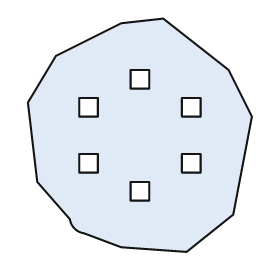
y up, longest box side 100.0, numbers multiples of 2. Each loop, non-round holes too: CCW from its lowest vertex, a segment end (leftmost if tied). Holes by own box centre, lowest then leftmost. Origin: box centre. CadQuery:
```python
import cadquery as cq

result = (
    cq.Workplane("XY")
    .moveTo(20.0, -50.0)
    .lineTo(40.0, -34.0)
    .lineTo(48.0, 8.0)
    .lineTo(38.0, 28.0)
    .lineTo(10.0, 50.0)
    .lineTo(-8.0, 48.0)
    .lineTo(-36.0, 34.0)
    .lineTo(-48.0, 14.0)
    .lineTo(-44.0, -20.0)
    .lineTo(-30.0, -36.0)
    .threePointArc((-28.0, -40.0), (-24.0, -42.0))
    .lineTo(-8.0, -48.0)
    .close()
    .moveTo(-4.0, -28.0)
    .lineTo(4.0, -28.0)
    .lineTo(4.0, -20.0)
    .lineTo(-4.0, -20.0)
    .close()
    .moveTo(-26.0, -16.0)
    .lineTo(-18.0, -16.0)
    .lineTo(-18.0, -8.0)
    .lineTo(-26.0, -8.0)
    .close()
    .moveTo(18.0, -16.0)
    .lineTo(26.0, -16.0)
    .lineTo(26.0, -8.0)
    .lineTo(18.0, -8.0)
    .close()
    .moveTo(-26.0, 8.0)
    .lineTo(-18.0, 8.0)
    .lineTo(-18.0, 16.0)
    .lineTo(-26.0, 16.0)
    .close()
    .moveTo(18.0, 8.0)
    .lineTo(26.0, 8.0)
    .lineTo(26.0, 16.0)
    .lineTo(18.0, 16.0)
    .close()
    .moveTo(-4.0, 20.0)
    .lineTo(4.0, 20.0)
    .lineTo(4.0, 28.0)
    .lineTo(-4.0, 28.0)
    .close()
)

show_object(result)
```